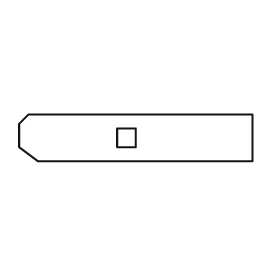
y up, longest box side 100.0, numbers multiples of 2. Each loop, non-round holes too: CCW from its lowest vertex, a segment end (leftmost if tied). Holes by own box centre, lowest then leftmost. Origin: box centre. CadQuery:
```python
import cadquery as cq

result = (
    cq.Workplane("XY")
    .moveTo(-42.0, -10.0)
    .lineTo(50.0, -10.0)
    .lineTo(50.0, 10.0)
    .lineTo(-46.0, 10.0)
    .lineTo(-50.0, 6.0)
    .lineTo(-50.0, -4.0)
    .close()
    .moveTo(-8.0, -4.0)
    .lineTo(0.0, -4.0)
    .lineTo(0.0, 4.0)
    .lineTo(-8.0, 4.0)
    .close()
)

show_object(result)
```